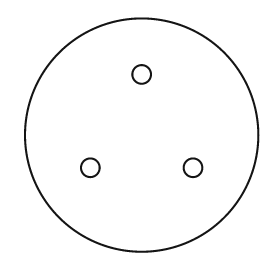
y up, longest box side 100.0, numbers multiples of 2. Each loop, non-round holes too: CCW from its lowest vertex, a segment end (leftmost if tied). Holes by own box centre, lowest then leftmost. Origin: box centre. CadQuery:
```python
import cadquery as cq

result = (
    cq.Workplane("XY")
    .moveTo(0.0, 0.0)
    .circle(50.0)
    .moveTo(-22.0, -14.0)
    .circle(4.0)
    .moveTo(22.0, -14.0)
    .circle(4.0)
    .moveTo(0.0, 26.0)
    .circle(4.0)
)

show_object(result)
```